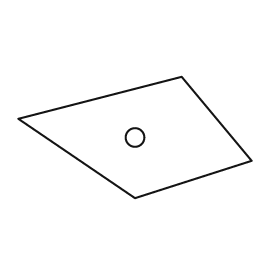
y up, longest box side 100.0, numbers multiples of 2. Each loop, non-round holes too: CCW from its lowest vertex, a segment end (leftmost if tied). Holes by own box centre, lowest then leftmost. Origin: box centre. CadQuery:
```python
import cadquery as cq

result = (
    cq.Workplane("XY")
    .moveTo(0.0, -26.0)
    .lineTo(50.0, -10.0)
    .lineTo(20.0, 26.0)
    .lineTo(-50.0, 8.0)
    .close()
    .moveTo(0.0, 0.0)
    .circle(4.0)
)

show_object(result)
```